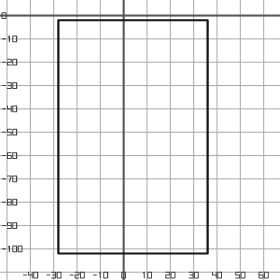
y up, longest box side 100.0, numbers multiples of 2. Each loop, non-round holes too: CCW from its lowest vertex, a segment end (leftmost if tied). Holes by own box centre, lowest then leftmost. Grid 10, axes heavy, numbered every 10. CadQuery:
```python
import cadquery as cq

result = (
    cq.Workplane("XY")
    .moveTo(-28.0, -102.0)
    .lineTo(36.0, -102.0)
    .lineTo(36.0, -2.0)
    .lineTo(-28.0, -2.0)
    .close()
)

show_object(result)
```